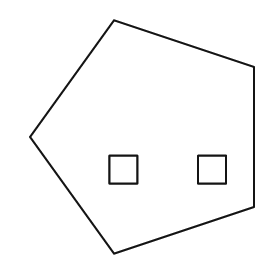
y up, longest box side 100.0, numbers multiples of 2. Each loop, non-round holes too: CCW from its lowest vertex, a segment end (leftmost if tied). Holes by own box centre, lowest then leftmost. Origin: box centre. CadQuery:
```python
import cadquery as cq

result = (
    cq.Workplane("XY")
    .moveTo(-12.0, -50.0)
    .lineTo(48.0, -30.0)
    .lineTo(48.0, 30.0)
    .lineTo(-12.0, 50.0)
    .lineTo(-48.0, 0.0)
    .close()
    .moveTo(-14.0, -20.0)
    .lineTo(-2.0, -20.0)
    .lineTo(-2.0, -8.0)
    .lineTo(-14.0, -8.0)
    .close()
    .moveTo(24.0, -20.0)
    .lineTo(36.0, -20.0)
    .lineTo(36.0, -8.0)
    .lineTo(24.0, -8.0)
    .close()
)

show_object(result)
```